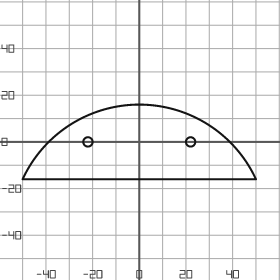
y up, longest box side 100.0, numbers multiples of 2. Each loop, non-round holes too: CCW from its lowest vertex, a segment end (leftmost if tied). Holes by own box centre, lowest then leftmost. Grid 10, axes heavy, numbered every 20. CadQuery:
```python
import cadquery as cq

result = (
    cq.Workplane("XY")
    .moveTo(-50.0, -16.0)
    .lineTo(50.0, -16.0)
    .threePointArc((0.0, 16.0), (-50.0, -16.0))
    .close()
    .moveTo(-22.0, 0.0)
    .circle(2.0)
    .moveTo(22.0, 0.0)
    .circle(2.0)
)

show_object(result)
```